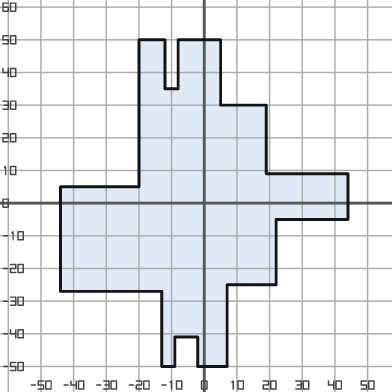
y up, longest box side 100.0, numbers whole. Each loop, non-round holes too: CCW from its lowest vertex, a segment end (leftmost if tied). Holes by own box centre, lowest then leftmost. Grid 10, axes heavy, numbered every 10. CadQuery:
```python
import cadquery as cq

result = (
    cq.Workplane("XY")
    .moveTo(-13.0, -50.0)
    .lineTo(-9.0, -50.0)
    .lineTo(-9.0, -41.0)
    .lineTo(-2.0, -41.0)
    .lineTo(-2.0, -50.0)
    .lineTo(7.0, -50.0)
    .lineTo(7.0, -25.0)
    .lineTo(22.0, -25.0)
    .lineTo(22.0, -5.0)
    .lineTo(44.0, -5.0)
    .lineTo(44.0, 9.0)
    .lineTo(19.0, 9.0)
    .lineTo(19.0, 30.0)
    .lineTo(5.0, 30.0)
    .lineTo(5.0, 50.0)
    .lineTo(-8.0, 50.0)
    .lineTo(-8.0, 35.0)
    .lineTo(-12.0, 35.0)
    .lineTo(-12.0, 50.0)
    .lineTo(-20.0, 50.0)
    .lineTo(-20.0, 5.0)
    .lineTo(-44.0, 5.0)
    .lineTo(-44.0, -27.0)
    .lineTo(-13.0, -27.0)
    .close()
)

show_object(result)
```